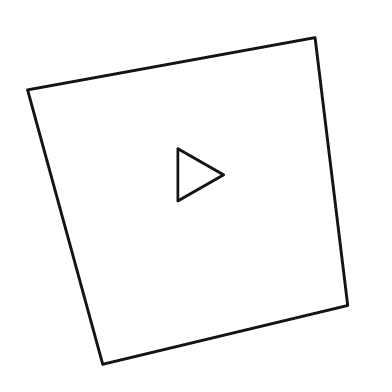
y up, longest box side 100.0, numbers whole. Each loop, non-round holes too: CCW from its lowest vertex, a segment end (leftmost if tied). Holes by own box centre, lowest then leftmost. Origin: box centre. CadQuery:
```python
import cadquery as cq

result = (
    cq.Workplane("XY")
    .moveTo(-26.0, -50.0)
    .lineTo(49.0, -32.0)
    .lineTo(39.0, 50.0)
    .lineTo(-49.0, 34.0)
    .close()
    .moveTo(-3.0, 0.0)
    .lineTo(11.0, 8.0)
    .lineTo(-3.0, 16.0)
    .close()
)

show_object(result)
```